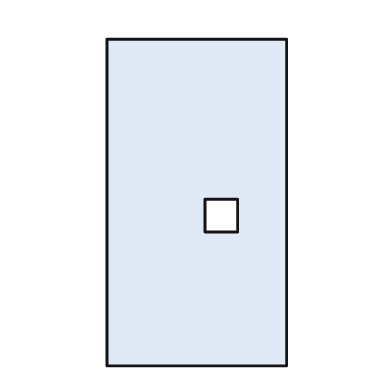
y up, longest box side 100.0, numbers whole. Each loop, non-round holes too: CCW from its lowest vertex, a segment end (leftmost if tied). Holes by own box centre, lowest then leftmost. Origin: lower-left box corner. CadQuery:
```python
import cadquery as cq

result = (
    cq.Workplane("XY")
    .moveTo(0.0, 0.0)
    .lineTo(55.0, 0.0)
    .lineTo(55.0, 100.0)
    .lineTo(0.0, 100.0)
    .close()
    .moveTo(30.0, 41.0)
    .lineTo(40.0, 41.0)
    .lineTo(40.0, 51.0)
    .lineTo(30.0, 51.0)
    .close()
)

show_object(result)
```